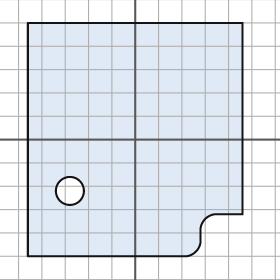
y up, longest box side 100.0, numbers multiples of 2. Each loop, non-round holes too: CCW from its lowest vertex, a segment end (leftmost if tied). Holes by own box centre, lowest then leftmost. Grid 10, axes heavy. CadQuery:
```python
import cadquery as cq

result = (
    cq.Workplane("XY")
    .moveTo(-46.0, -50.0)
    .lineTo(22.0, -50.0)
    .threePointArc((26.0, -48.0), (28.0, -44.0))
    .lineTo(28.0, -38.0)
    .threePointArc((30.0, -34.0), (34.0, -32.0))
    .lineTo(46.0, -32.0)
    .lineTo(46.0, 50.0)
    .lineTo(-46.0, 50.0)
    .close()
    .moveTo(-28.0, -22.0)
    .circle(6.0)
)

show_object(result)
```